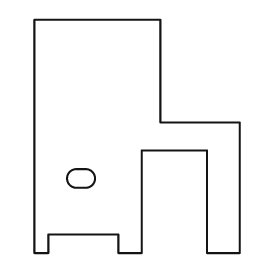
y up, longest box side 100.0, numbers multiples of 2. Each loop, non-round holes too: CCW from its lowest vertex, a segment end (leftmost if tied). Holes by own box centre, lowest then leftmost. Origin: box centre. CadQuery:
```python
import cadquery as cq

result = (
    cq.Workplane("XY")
    .moveTo(-44.0, -50.0)
    .lineTo(-38.0, -50.0)
    .lineTo(-38.0, -42.0)
    .lineTo(-8.0, -42.0)
    .lineTo(-8.0, -50.0)
    .lineTo(2.0, -50.0)
    .lineTo(2.0, -6.0)
    .lineTo(30.0, -6.0)
    .lineTo(30.0, -50.0)
    .lineTo(44.0, -50.0)
    .lineTo(44.0, 6.0)
    .lineTo(10.0, 6.0)
    .lineTo(10.0, 50.0)
    .lineTo(-44.0, 50.0)
    .close()
    .moveTo(-26.0, -22.0)
    .lineTo(-22.0, -22.0)
    .threePointArc((-18.0, -18.0), (-22.0, -14.0))
    .lineTo(-26.0, -14.0)
    .threePointArc((-30.0, -18.0), (-26.0, -22.0))
    .close()
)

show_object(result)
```